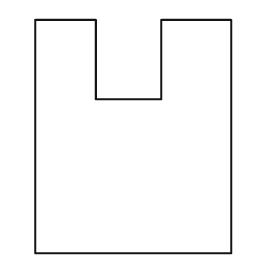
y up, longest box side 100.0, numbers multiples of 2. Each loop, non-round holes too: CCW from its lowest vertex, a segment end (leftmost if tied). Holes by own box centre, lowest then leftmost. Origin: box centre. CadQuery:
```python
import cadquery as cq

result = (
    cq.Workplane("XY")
    .moveTo(-42.0, -50.0)
    .lineTo(42.0, -50.0)
    .lineTo(42.0, 50.0)
    .lineTo(12.0, 50.0)
    .lineTo(12.0, 16.0)
    .lineTo(-16.0, 16.0)
    .lineTo(-16.0, 50.0)
    .lineTo(-42.0, 50.0)
    .close()
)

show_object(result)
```